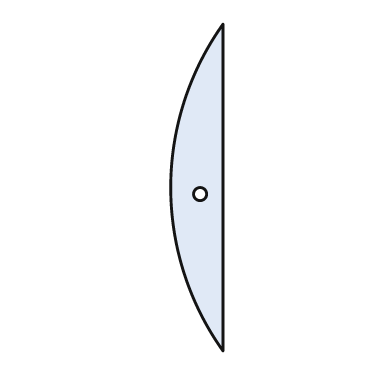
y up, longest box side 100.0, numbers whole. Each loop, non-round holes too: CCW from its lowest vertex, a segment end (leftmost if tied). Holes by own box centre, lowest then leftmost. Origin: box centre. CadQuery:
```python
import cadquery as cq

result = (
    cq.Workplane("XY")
    .moveTo(8.0, -50.0)
    .lineTo(8.0, 50.0)
    .threePointArc((-8.0, 0.0), (8.0, -50.0))
    .close()
    .moveTo(1.0, -2.0)
    .circle(2.0)
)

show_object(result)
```